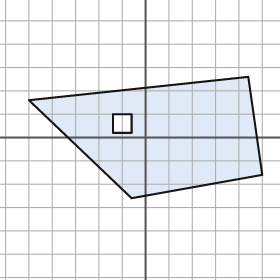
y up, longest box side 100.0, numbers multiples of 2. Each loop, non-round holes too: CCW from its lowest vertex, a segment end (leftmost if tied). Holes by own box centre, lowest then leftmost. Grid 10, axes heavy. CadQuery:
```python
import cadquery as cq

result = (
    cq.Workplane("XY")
    .moveTo(-6.0, -26.0)
    .lineTo(50.0, -16.0)
    .lineTo(44.0, 26.0)
    .lineTo(-50.0, 16.0)
    .close()
    .moveTo(-14.0, 2.0)
    .lineTo(-6.0, 2.0)
    .lineTo(-6.0, 10.0)
    .lineTo(-14.0, 10.0)
    .close()
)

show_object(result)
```